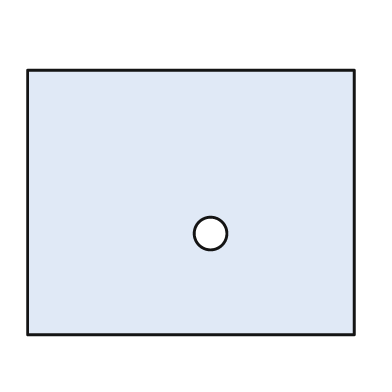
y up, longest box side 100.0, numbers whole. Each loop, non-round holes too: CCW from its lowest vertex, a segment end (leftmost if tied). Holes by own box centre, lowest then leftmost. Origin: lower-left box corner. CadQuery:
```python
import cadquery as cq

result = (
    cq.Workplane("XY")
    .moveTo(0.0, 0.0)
    .lineTo(100.0, 0.0)
    .lineTo(100.0, 81.0)
    .lineTo(0.0, 81.0)
    .close()
    .moveTo(56.0, 31.0)
    .circle(5.0)
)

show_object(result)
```